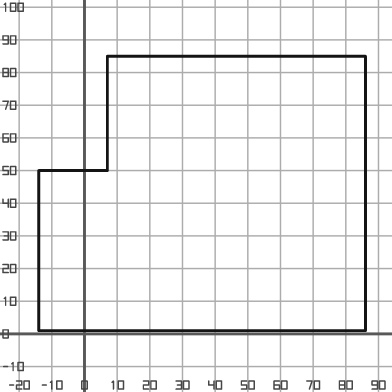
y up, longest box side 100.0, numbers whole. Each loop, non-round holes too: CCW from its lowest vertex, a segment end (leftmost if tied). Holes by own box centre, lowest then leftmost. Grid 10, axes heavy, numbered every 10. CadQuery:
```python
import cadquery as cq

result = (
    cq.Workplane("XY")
    .moveTo(-14.0, 1.0)
    .lineTo(86.0, 1.0)
    .lineTo(86.0, 85.0)
    .lineTo(7.0, 85.0)
    .lineTo(7.0, 50.0)
    .lineTo(-14.0, 50.0)
    .close()
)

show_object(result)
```